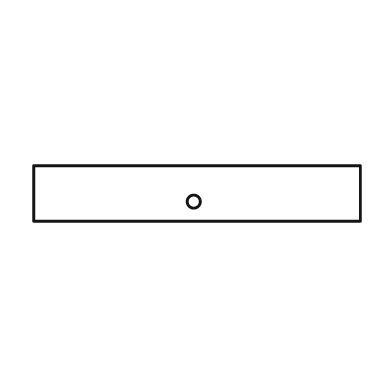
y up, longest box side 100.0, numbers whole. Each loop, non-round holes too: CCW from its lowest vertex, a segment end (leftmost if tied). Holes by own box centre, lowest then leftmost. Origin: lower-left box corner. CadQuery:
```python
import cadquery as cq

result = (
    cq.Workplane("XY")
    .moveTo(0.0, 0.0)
    .lineTo(100.0, 0.0)
    .lineTo(100.0, 17.0)
    .lineTo(0.0, 17.0)
    .close()
    .moveTo(49.0, 6.0)
    .circle(2.0)
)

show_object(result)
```